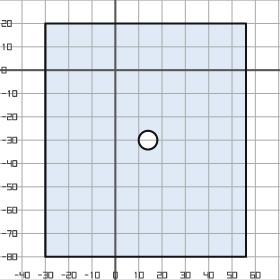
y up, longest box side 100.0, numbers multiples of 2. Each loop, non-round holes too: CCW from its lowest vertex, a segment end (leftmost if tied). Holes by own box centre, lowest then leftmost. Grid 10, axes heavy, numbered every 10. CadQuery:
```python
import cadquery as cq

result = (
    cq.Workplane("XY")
    .moveTo(-30.0, -80.0)
    .lineTo(56.0, -80.0)
    .lineTo(56.0, 20.0)
    .lineTo(-30.0, 20.0)
    .close()
    .moveTo(14.0, -30.0)
    .circle(4.0)
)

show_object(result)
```